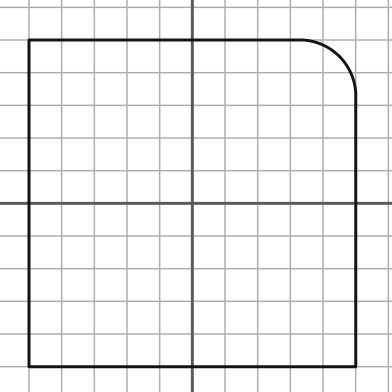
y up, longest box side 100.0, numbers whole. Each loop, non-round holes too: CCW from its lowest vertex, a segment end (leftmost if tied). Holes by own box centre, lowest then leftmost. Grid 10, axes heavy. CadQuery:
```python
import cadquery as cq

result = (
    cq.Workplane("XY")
    .moveTo(-50.0, -50.0)
    .lineTo(50.0, -50.0)
    .lineTo(50.0, 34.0)
    .threePointArc((45.0, 45.0), (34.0, 50.0))
    .lineTo(-50.0, 50.0)
    .close()
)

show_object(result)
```